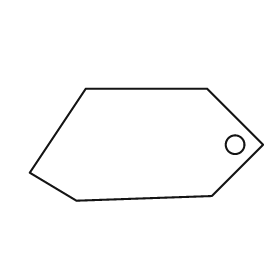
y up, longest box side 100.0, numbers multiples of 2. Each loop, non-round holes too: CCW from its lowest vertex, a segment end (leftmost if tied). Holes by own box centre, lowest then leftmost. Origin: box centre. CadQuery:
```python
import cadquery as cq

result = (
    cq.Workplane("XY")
    .moveTo(-30.0, -24.0)
    .lineTo(28.0, -22.0)
    .lineTo(50.0, 0.0)
    .lineTo(26.0, 24.0)
    .lineTo(-26.0, 24.0)
    .lineTo(-50.0, -12.0)
    .close()
    .moveTo(38.0, 0.0)
    .circle(4.0)
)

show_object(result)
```